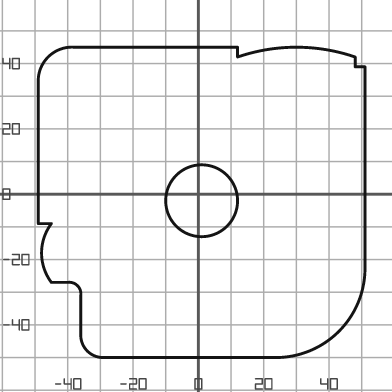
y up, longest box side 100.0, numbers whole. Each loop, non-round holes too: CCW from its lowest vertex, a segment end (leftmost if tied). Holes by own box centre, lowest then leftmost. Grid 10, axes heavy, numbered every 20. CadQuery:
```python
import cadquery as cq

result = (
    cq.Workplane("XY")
    .moveTo(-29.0, -50.0)
    .lineTo(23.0, -50.0)
    .threePointArc((43.0, -42.0), (51.0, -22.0))
    .lineTo(51.0, 39.0)
    .lineTo(48.0, 39.0)
    .lineTo(48.0, 42.0)
    .threePointArc((30.0, 45.0), (12.0, 42.0))
    .lineTo(12.0, 45.0)
    .lineTo(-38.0, 45.0)
    .threePointArc((-46.0, 42.0), (-49.0, 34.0))
    .lineTo(-49.0, -9.0)
    .lineTo(-45.0, -9.0)
    .threePointArc((-48.0, -18.0), (-45.0, -27.0))
    .lineTo(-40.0, -27.0)
    .threePointArc((-37.0, -28.0), (-36.0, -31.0))
    .lineTo(-36.0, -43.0)
    .threePointArc((-34.0, -48.0), (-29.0, -50.0))
    .close()
    .moveTo(1.0, -2.0)
    .circle(11.0)
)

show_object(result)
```